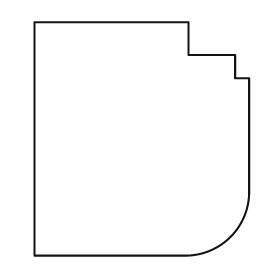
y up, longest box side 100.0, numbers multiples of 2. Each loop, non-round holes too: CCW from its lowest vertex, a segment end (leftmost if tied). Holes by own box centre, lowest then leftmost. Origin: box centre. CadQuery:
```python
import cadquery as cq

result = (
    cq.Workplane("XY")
    .moveTo(-46.0, -50.0)
    .lineTo(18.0, -50.0)
    .threePointArc((38.0, -42.0), (46.0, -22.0))
    .lineTo(46.0, 26.0)
    .lineTo(40.0, 26.0)
    .lineTo(40.0, 36.0)
    .lineTo(20.0, 36.0)
    .lineTo(20.0, 50.0)
    .lineTo(-46.0, 50.0)
    .close()
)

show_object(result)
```